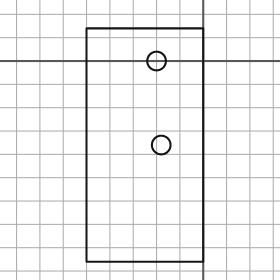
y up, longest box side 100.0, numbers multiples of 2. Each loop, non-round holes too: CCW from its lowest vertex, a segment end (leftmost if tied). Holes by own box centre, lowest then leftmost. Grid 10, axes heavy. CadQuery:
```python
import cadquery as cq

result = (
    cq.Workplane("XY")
    .moveTo(-50.0, -86.0)
    .lineTo(0.0, -86.0)
    .lineTo(0.0, 14.0)
    .lineTo(-50.0, 14.0)
    .close()
    .moveTo(-18.0, -36.0)
    .circle(4.0)
    .moveTo(-20.0, 0.0)
    .circle(4.0)
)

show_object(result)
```